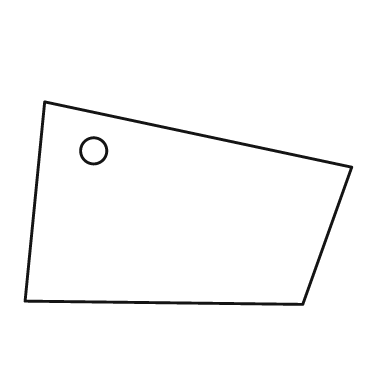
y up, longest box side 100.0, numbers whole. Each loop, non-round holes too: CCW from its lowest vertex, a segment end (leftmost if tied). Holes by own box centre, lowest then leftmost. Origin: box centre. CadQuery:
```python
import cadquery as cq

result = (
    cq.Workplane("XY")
    .moveTo(35.0, -31.0)
    .lineTo(50.0, 11.0)
    .lineTo(-44.0, 31.0)
    .lineTo(-50.0, -30.0)
    .close()
    .moveTo(-29.0, 16.0)
    .circle(4.0)
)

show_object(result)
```